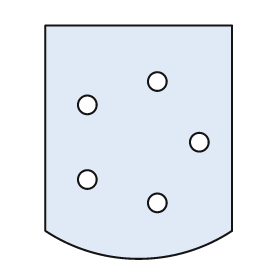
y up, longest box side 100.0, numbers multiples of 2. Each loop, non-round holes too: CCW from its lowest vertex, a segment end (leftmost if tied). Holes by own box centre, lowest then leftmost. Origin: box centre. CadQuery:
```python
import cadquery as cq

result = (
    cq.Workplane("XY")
    .moveTo(-40.0, -38.0)
    .threePointArc((0.0, -50.0), (40.0, -38.0))
    .lineTo(40.0, 50.0)
    .lineTo(-40.0, 50.0)
    .close()
    .moveTo(8.0, -26.0)
    .circle(4.0)
    .moveTo(-22.0, -16.0)
    .circle(4.0)
    .moveTo(26.0, 0.0)
    .circle(4.0)
    .moveTo(-22.0, 16.0)
    .circle(4.0)
    .moveTo(8.0, 26.0)
    .circle(4.0)
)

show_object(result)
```